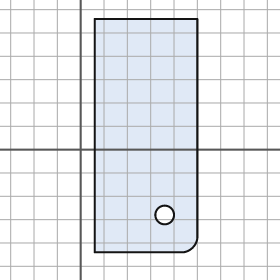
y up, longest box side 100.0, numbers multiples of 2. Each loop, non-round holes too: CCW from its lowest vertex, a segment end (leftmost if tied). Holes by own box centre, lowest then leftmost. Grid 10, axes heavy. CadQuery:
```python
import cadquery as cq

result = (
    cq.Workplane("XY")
    .moveTo(6.0, -44.0)
    .lineTo(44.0, -44.0)
    .threePointArc((48.0, -42.0), (50.0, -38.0))
    .lineTo(50.0, 56.0)
    .lineTo(6.0, 56.0)
    .close()
    .moveTo(36.0, -28.0)
    .circle(4.0)
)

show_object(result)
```